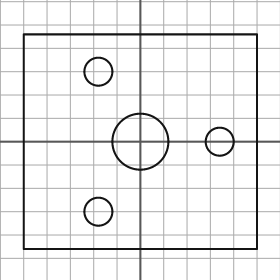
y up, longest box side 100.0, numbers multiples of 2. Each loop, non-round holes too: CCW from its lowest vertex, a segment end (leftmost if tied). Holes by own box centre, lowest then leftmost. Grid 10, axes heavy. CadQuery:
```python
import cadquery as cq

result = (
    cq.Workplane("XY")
    .moveTo(-50.0, -46.0)
    .lineTo(50.0, -46.0)
    .lineTo(50.0, 46.0)
    .lineTo(-50.0, 46.0)
    .close()
    .moveTo(-18.0, -30.0)
    .circle(6.0)
    .moveTo(0.0, 0.0)
    .circle(12.0)
    .moveTo(34.0, 0.0)
    .circle(6.0)
    .moveTo(-18.0, 30.0)
    .circle(6.0)
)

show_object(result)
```